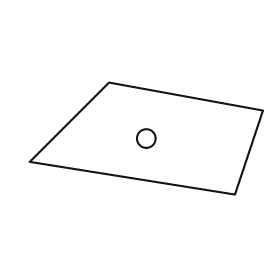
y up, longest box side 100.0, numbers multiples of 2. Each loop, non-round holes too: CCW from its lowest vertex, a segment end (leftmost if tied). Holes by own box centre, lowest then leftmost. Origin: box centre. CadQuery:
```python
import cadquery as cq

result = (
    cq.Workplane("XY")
    .moveTo(38.0, -24.0)
    .lineTo(50.0, 12.0)
    .lineTo(-16.0, 24.0)
    .lineTo(-50.0, -10.0)
    .close()
    .moveTo(0.0, 0.0)
    .circle(4.0)
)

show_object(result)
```